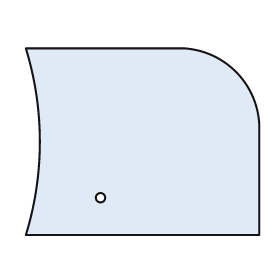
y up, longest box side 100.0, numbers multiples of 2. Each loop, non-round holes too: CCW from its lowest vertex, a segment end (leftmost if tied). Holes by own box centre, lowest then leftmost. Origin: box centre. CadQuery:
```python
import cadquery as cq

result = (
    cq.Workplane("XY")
    .moveTo(-50.0, -40.0)
    .lineTo(50.0, -40.0)
    .lineTo(50.0, 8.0)
    .threePointArc((40.0, 30.0), (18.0, 40.0))
    .lineTo(-50.0, 40.0)
    .threePointArc((-44.0, 0.0), (-50.0, -40.0))
    .close()
    .moveTo(-18.0, -24.0)
    .circle(2.0)
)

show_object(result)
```